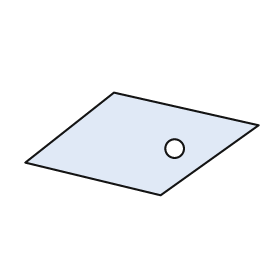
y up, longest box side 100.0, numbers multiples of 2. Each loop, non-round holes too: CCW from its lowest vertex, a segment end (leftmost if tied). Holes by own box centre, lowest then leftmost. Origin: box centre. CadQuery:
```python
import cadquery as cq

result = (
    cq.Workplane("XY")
    .moveTo(8.0, -22.0)
    .lineTo(50.0, 8.0)
    .lineTo(-12.0, 22.0)
    .lineTo(-50.0, -8.0)
    .close()
    .moveTo(14.0, -2.0)
    .circle(4.0)
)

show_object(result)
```